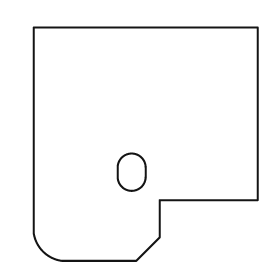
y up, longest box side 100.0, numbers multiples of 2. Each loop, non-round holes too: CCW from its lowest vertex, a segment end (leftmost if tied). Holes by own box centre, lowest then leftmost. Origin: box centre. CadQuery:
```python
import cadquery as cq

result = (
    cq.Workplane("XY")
    .moveTo(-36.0, -50.0)
    .lineTo(-4.0, -50.0)
    .lineTo(6.0, -40.0)
    .lineTo(6.0, -24.0)
    .lineTo(48.0, -24.0)
    .lineTo(48.0, 50.0)
    .lineTo(-48.0, 50.0)
    .lineTo(-48.0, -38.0)
    .threePointArc((-44.0, -46.0), (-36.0, -50.0))
    .close()
    .moveTo(-12.0, -14.0)
    .threePointArc((-6.0, -20.0), (0.0, -14.0))
    .lineTo(0.0, -10.0)
    .threePointArc((-6.0, -4.0), (-12.0, -10.0))
    .close()
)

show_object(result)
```